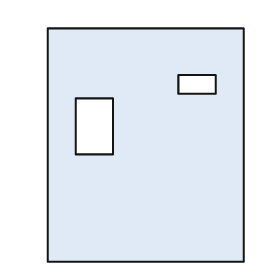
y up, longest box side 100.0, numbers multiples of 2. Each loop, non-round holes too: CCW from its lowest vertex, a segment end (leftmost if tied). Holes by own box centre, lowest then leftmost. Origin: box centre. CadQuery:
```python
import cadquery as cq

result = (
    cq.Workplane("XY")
    .moveTo(-42.0, -50.0)
    .lineTo(42.0, -50.0)
    .lineTo(42.0, 50.0)
    .lineTo(-42.0, 50.0)
    .close()
    .moveTo(-30.0, -4.0)
    .lineTo(-14.0, -4.0)
    .lineTo(-14.0, 20.0)
    .lineTo(-30.0, 20.0)
    .close()
    .moveTo(14.0, 22.0)
    .lineTo(30.0, 22.0)
    .lineTo(30.0, 30.0)
    .lineTo(14.0, 30.0)
    .close()
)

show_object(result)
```